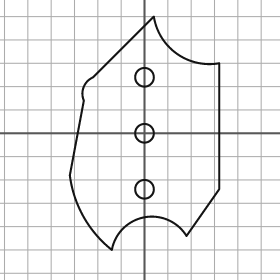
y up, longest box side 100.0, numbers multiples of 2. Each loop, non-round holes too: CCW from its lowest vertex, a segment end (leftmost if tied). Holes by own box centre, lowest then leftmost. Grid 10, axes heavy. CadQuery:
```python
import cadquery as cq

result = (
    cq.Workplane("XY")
    .moveTo(-14.0, -50.0)
    .threePointArc((0.0, -36.0), (18.0, -44.0))
    .lineTo(32.0, -24.0)
    .lineTo(32.0, 30.0)
    .threePointArc((14.0, 34.0), (4.0, 50.0))
    .lineTo(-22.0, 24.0)
    .threePointArc((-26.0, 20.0), (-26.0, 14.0))
    .lineTo(-32.0, -18.0)
    .threePointArc((-26.0, -36.0), (-14.0, -50.0))
    .close()
    .moveTo(0.0, -24.0)
    .circle(4.0)
    .moveTo(0.0, 0.0)
    .circle(4.0)
    .moveTo(0.0, 24.0)
    .circle(4.0)
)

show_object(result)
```